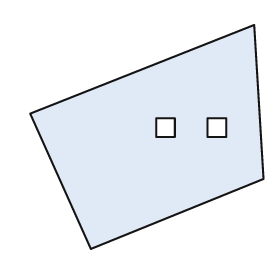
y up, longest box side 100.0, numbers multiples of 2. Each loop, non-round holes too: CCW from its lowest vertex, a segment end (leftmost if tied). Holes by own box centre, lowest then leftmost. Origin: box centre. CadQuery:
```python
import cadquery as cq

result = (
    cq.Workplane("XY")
    .moveTo(-24.0, -48.0)
    .lineTo(50.0, -18.0)
    .lineTo(46.0, 48.0)
    .lineTo(-50.0, 10.0)
    .close()
    .moveTo(4.0, 0.0)
    .lineTo(12.0, 0.0)
    .lineTo(12.0, 8.0)
    .lineTo(4.0, 8.0)
    .close()
    .moveTo(26.0, 0.0)
    .lineTo(34.0, 0.0)
    .lineTo(34.0, 8.0)
    .lineTo(26.0, 8.0)
    .close()
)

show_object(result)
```